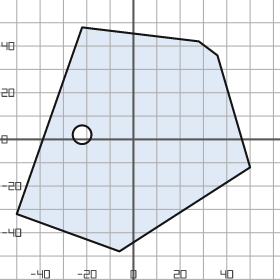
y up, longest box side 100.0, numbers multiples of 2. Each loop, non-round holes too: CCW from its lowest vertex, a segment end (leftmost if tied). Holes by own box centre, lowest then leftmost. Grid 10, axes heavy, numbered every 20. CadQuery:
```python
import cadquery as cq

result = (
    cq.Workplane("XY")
    .moveTo(-6.0, -48.0)
    .lineTo(50.0, -12.0)
    .lineTo(36.0, 36.0)
    .lineTo(28.0, 42.0)
    .lineTo(-22.0, 48.0)
    .lineTo(-50.0, -32.0)
    .close()
    .moveTo(-22.0, 2.0)
    .circle(4.0)
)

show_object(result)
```